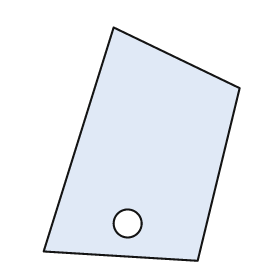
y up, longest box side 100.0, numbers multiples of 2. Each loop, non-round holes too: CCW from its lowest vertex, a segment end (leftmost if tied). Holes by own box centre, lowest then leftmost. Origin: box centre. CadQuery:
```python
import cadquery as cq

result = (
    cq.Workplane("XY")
    .moveTo(24.0, -50.0)
    .lineTo(42.0, 24.0)
    .lineTo(-12.0, 50.0)
    .lineTo(-42.0, -46.0)
    .close()
    .moveTo(-6.0, -34.0)
    .circle(6.0)
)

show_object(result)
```